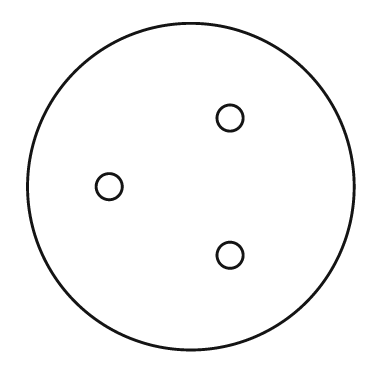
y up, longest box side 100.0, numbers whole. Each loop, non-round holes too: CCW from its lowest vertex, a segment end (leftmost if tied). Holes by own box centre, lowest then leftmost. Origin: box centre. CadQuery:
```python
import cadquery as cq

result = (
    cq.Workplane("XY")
    .moveTo(0.0, 0.0)
    .circle(50.0)
    .moveTo(12.0, -21.0)
    .circle(4.0)
    .moveTo(-25.0, 0.0)
    .circle(4.0)
    .moveTo(12.0, 21.0)
    .circle(4.0)
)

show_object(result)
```